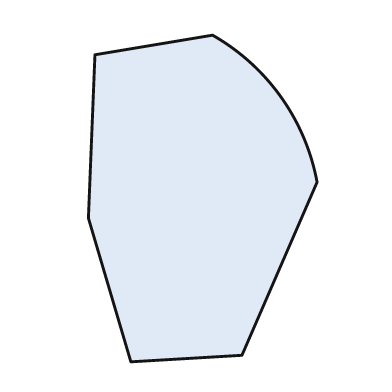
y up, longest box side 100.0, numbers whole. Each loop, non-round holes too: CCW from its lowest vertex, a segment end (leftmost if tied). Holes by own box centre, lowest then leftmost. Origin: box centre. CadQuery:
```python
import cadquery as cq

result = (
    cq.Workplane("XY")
    .moveTo(-22.0, -50.0)
    .lineTo(12.0, -48.0)
    .lineTo(35.0, 5.0)
    .threePointArc((24.0, 31.0), (3.0, 50.0))
    .lineTo(-33.0, 44.0)
    .lineTo(-35.0, -6.0)
    .close()
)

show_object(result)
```